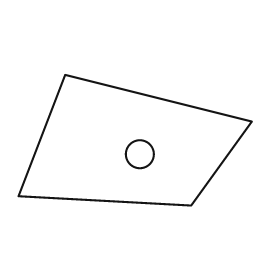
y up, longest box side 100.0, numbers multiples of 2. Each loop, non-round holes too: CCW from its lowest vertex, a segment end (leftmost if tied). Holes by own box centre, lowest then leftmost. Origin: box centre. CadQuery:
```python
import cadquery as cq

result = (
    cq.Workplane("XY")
    .moveTo(24.0, -28.0)
    .lineTo(50.0, 8.0)
    .lineTo(-30.0, 28.0)
    .lineTo(-50.0, -24.0)
    .close()
    .moveTo(2.0, -6.0)
    .circle(6.0)
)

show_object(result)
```